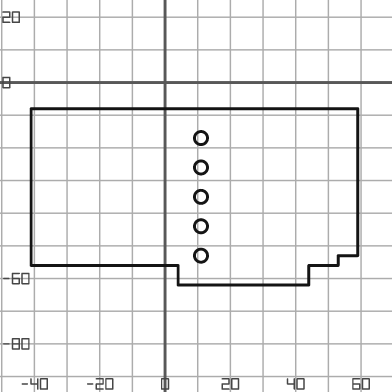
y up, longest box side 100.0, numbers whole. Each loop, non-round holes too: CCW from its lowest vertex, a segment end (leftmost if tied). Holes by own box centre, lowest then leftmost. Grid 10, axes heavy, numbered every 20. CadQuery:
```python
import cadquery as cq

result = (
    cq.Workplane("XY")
    .moveTo(4.0, -62.0)
    .lineTo(44.0, -62.0)
    .lineTo(44.0, -56.0)
    .lineTo(53.0, -56.0)
    .lineTo(53.0, -53.0)
    .lineTo(59.0, -53.0)
    .lineTo(59.0, -8.0)
    .lineTo(-41.0, -8.0)
    .lineTo(-41.0, -56.0)
    .lineTo(4.0, -56.0)
    .close()
    .moveTo(11.0, -53.0)
    .circle(2.0)
    .moveTo(11.0, -44.0)
    .circle(2.0)
    .moveTo(11.0, -35.0)
    .circle(2.0)
    .moveTo(11.0, -26.0)
    .circle(2.0)
    .moveTo(11.0, -17.0)
    .circle(2.0)
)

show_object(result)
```